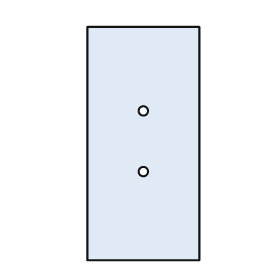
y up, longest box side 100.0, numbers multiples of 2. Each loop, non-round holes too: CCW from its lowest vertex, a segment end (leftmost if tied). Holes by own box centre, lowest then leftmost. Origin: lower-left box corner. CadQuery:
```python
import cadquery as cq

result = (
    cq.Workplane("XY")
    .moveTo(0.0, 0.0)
    .lineTo(48.0, 0.0)
    .lineTo(48.0, 100.0)
    .lineTo(0.0, 100.0)
    .close()
    .moveTo(24.0, 38.0)
    .circle(2.0)
    .moveTo(24.0, 64.0)
    .circle(2.0)
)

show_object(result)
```